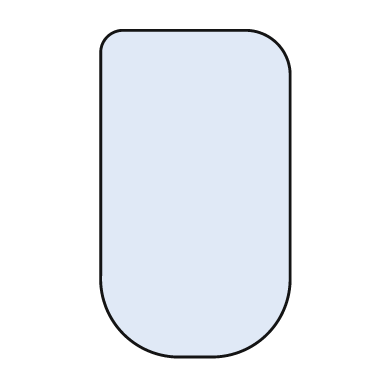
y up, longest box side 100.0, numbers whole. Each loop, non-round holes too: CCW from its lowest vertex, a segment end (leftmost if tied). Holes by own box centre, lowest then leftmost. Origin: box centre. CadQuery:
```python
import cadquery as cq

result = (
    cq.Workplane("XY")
    .moveTo(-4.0, -50.0)
    .lineTo(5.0, -50.0)
    .threePointArc((22.0, -43.0), (29.0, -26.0))
    .lineTo(29.0, 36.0)
    .threePointArc((25.0, 46.0), (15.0, 50.0))
    .lineTo(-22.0, 50.0)
    .threePointArc((-27.0, 48.0), (-29.0, 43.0))
    .lineTo(-29.0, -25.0)
    .threePointArc((-22.0, -43.0), (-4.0, -50.0))
    .close()
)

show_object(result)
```